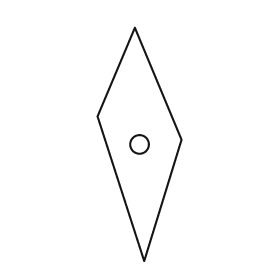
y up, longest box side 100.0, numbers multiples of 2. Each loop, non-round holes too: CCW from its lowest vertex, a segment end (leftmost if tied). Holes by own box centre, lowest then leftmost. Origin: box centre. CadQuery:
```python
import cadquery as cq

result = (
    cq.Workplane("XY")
    .moveTo(2.0, -50.0)
    .lineTo(18.0, 2.0)
    .lineTo(-2.0, 50.0)
    .lineTo(-18.0, 12.0)
    .close()
    .moveTo(0.0, 0.0)
    .circle(4.0)
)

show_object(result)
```